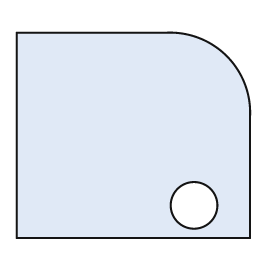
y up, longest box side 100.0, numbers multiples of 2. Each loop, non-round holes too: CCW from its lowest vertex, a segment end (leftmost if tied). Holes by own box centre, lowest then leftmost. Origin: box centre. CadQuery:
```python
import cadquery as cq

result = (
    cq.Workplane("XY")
    .moveTo(-50.0, -44.0)
    .lineTo(50.0, -44.0)
    .lineTo(50.0, 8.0)
    .threePointArc((40.0, 34.0), (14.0, 44.0))
    .lineTo(-50.0, 44.0)
    .close()
    .moveTo(26.0, -30.0)
    .circle(10.0)
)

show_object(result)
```